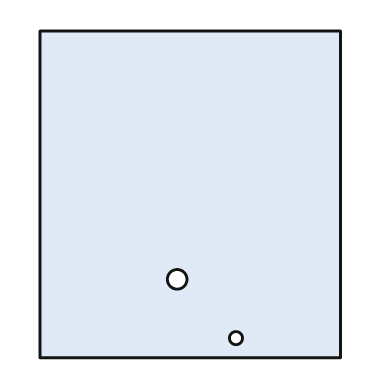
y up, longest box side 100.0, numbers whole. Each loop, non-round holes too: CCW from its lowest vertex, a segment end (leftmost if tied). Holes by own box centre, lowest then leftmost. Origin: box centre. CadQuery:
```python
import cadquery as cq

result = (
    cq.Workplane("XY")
    .moveTo(-46.0, -50.0)
    .lineTo(46.0, -50.0)
    .lineTo(46.0, 50.0)
    .lineTo(-46.0, 50.0)
    .close()
    .moveTo(14.0, -44.0)
    .circle(2.0)
    .moveTo(-4.0, -26.0)
    .circle(3.0)
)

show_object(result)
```